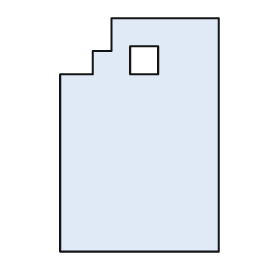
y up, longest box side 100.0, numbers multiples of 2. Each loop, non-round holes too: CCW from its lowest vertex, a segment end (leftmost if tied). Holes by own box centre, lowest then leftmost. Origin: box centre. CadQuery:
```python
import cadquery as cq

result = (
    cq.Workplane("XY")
    .moveTo(-34.0, -50.0)
    .lineTo(34.0, -50.0)
    .lineTo(34.0, 50.0)
    .lineTo(-12.0, 50.0)
    .lineTo(-12.0, 36.0)
    .lineTo(-20.0, 36.0)
    .lineTo(-20.0, 26.0)
    .lineTo(-34.0, 26.0)
    .close()
    .moveTo(-4.0, 26.0)
    .lineTo(8.0, 26.0)
    .lineTo(8.0, 38.0)
    .lineTo(-4.0, 38.0)
    .close()
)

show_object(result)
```